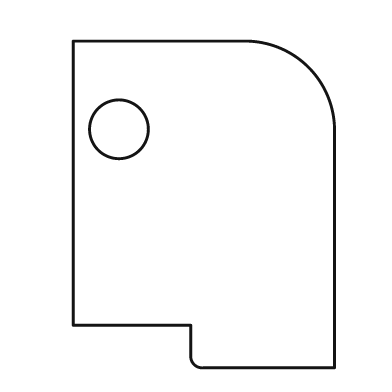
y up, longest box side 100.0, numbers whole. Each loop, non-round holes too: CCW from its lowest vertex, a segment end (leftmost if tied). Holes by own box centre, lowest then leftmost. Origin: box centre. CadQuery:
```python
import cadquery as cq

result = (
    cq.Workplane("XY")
    .moveTo(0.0, -50.0)
    .lineTo(40.0, -50.0)
    .lineTo(40.0, 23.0)
    .threePointArc((32.0, 42.0), (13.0, 50.0))
    .lineTo(-40.0, 50.0)
    .lineTo(-40.0, -37.0)
    .lineTo(-4.0, -37.0)
    .lineTo(-4.0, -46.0)
    .threePointArc((-3.0, -49.0), (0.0, -50.0))
    .close()
    .moveTo(-26.0, 23.0)
    .circle(9.0)
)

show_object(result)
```